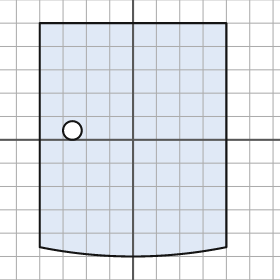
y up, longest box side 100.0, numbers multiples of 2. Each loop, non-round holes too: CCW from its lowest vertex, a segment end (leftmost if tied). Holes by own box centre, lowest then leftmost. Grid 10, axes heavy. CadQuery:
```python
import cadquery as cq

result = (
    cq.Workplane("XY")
    .moveTo(-40.0, -46.0)
    .threePointArc((0.0, -50.0), (40.0, -46.0))
    .lineTo(40.0, 50.0)
    .lineTo(-40.0, 50.0)
    .close()
    .moveTo(-26.0, 4.0)
    .circle(4.0)
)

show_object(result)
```